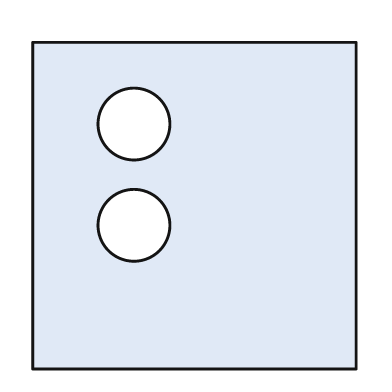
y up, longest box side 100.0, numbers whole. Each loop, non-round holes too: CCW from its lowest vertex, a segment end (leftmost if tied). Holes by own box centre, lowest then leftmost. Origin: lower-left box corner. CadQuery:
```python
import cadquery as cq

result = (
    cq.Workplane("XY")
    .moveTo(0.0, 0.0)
    .lineTo(99.0, 0.0)
    .lineTo(99.0, 100.0)
    .lineTo(0.0, 100.0)
    .close()
    .moveTo(31.0, 44.0)
    .circle(11.0)
    .moveTo(31.0, 75.0)
    .circle(11.0)
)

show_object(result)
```